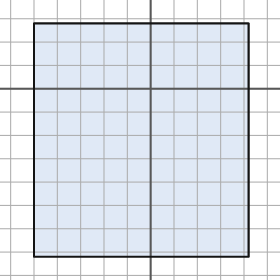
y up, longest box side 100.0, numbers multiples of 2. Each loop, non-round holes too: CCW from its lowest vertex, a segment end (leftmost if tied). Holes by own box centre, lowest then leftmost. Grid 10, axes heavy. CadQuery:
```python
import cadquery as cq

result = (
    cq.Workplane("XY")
    .moveTo(-50.0, -72.0)
    .lineTo(42.0, -72.0)
    .lineTo(42.0, 28.0)
    .lineTo(-50.0, 28.0)
    .close()
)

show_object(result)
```